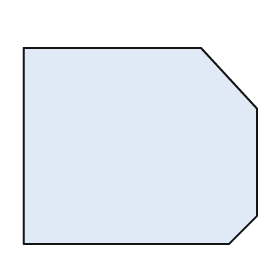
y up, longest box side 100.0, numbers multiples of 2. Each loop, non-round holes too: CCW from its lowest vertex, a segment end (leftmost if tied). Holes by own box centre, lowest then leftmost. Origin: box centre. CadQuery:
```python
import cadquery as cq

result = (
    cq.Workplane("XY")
    .moveTo(-50.0, -42.0)
    .lineTo(38.0, -42.0)
    .lineTo(50.0, -30.0)
    .lineTo(50.0, 16.0)
    .lineTo(26.0, 42.0)
    .lineTo(-50.0, 42.0)
    .close()
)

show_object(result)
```